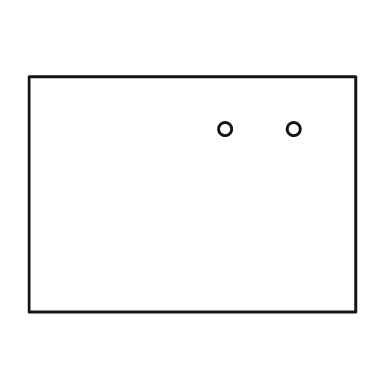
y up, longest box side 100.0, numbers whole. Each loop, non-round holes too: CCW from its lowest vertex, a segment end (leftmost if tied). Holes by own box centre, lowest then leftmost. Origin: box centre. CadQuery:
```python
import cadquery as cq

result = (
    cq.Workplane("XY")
    .moveTo(-50.0, -36.0)
    .lineTo(50.0, -36.0)
    .lineTo(50.0, 36.0)
    .lineTo(-50.0, 36.0)
    .close()
    .moveTo(10.0, 20.0)
    .circle(2.0)
    .moveTo(31.0, 20.0)
    .circle(2.0)
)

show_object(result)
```